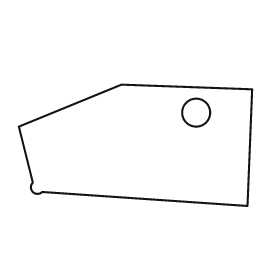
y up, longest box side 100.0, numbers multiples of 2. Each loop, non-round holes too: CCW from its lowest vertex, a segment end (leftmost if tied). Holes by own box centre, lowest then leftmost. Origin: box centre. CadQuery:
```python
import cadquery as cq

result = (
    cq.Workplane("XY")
    .moveTo(48.0, -26.0)
    .lineTo(50.0, 24.0)
    .lineTo(-6.0, 26.0)
    .lineTo(-50.0, 8.0)
    .lineTo(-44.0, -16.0)
    .threePointArc((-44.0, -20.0), (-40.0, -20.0))
    .close()
    .moveTo(26.0, 14.0)
    .circle(6.0)
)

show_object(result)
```